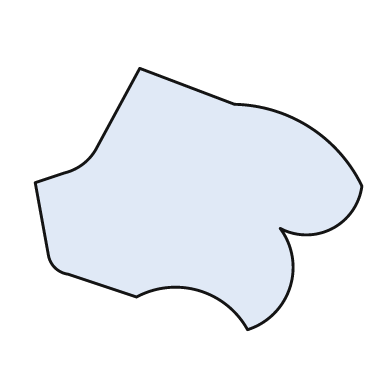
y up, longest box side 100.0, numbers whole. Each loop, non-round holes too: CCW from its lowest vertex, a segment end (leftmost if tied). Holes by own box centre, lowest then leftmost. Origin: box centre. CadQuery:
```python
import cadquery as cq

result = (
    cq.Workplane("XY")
    .moveTo(15.0, -40.0)
    .threePointArc((28.0, -27.0), (25.0, -9.0))
    .threePointArc((41.0, -9.0), (50.0, 4.0))
    .threePointArc((34.0, 22.0), (11.0, 29.0))
    .lineTo(-18.0, 40.0)
    .lineTo(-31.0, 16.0)
    .threePointArc((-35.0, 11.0), (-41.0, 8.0))
    .lineTo(-50.0, 5.0)
    .lineTo(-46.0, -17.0)
    .threePointArc((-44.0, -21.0), (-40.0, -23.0))
    .lineTo(-19.0, -30.0)
    .threePointArc((0.0, -28.0), (15.0, -40.0))
    .close()
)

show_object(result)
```